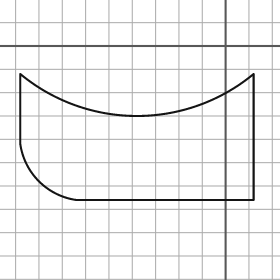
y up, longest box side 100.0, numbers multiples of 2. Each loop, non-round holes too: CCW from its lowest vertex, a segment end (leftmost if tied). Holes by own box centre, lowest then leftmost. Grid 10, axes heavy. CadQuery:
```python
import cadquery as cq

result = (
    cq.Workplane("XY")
    .moveTo(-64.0, -66.0)
    .lineTo(12.0, -66.0)
    .lineTo(12.0, -12.0)
    .threePointArc((-38.0, -30.0), (-88.0, -12.0))
    .lineTo(-88.0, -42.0)
    .threePointArc((-80.0, -58.0), (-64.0, -66.0))
    .close()
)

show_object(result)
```